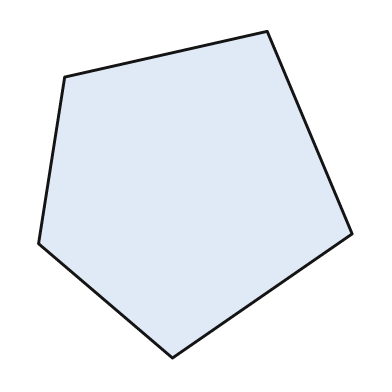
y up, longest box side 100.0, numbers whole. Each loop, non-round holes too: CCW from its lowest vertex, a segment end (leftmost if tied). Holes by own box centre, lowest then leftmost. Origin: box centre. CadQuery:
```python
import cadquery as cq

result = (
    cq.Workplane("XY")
    .moveTo(-7.0, -50.0)
    .lineTo(48.0, -12.0)
    .lineTo(22.0, 50.0)
    .lineTo(-40.0, 36.0)
    .lineTo(-48.0, -15.0)
    .close()
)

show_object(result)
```